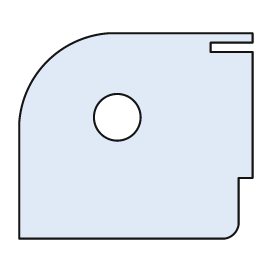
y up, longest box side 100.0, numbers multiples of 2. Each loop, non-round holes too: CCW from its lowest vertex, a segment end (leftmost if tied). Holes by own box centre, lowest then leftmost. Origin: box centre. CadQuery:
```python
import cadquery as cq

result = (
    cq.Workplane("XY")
    .moveTo(-50.0, -44.0)
    .lineTo(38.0, -44.0)
    .threePointArc((42.0, -42.0), (44.0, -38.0))
    .lineTo(44.0, -18.0)
    .lineTo(50.0, -18.0)
    .lineTo(50.0, 36.0)
    .lineTo(32.0, 36.0)
    .lineTo(32.0, 40.0)
    .lineTo(50.0, 40.0)
    .lineTo(50.0, 44.0)
    .lineTo(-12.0, 44.0)
    .threePointArc((-38.0, 32.0), (-50.0, 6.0))
    .close()
    .moveTo(-8.0, 8.0)
    .circle(10.0)
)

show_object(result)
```